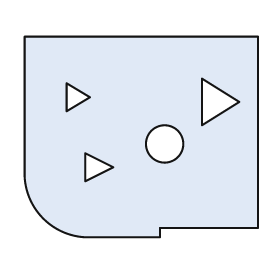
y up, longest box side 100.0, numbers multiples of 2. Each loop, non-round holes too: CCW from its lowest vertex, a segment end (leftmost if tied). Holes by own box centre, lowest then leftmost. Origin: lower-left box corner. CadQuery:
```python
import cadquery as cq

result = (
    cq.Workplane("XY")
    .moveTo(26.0, 0.0)
    .lineTo(58.0, 0.0)
    .lineTo(58.0, 4.0)
    .lineTo(100.0, 4.0)
    .lineTo(100.0, 86.0)
    .lineTo(0.0, 86.0)
    .lineTo(0.0, 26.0)
    .threePointArc((8.0, 8.0), (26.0, 0.0))
    .close()
    .moveTo(26.0, 24.0)
    .lineTo(38.0, 30.0)
    .lineTo(26.0, 36.0)
    .close()
    .moveTo(60.0, 40.0)
    .circle(8.0)
    .moveTo(76.0, 48.0)
    .lineTo(92.0, 58.0)
    .lineTo(76.0, 68.0)
    .close()
    .moveTo(18.0, 54.0)
    .lineTo(28.0, 60.0)
    .lineTo(18.0, 66.0)
    .close()
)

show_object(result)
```